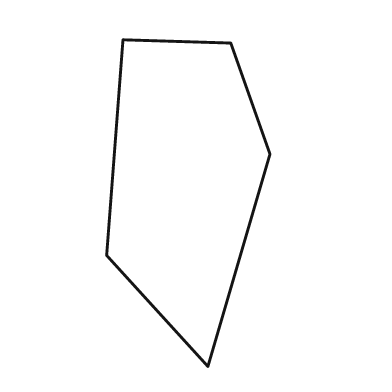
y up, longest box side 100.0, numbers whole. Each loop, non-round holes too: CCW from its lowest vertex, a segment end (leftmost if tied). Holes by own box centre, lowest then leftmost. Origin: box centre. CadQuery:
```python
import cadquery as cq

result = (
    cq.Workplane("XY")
    .moveTo(6.0, -50.0)
    .lineTo(25.0, 15.0)
    .lineTo(13.0, 49.0)
    .lineTo(-20.0, 50.0)
    .lineTo(-25.0, -16.0)
    .close()
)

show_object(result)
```